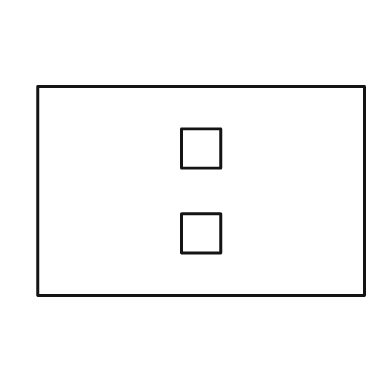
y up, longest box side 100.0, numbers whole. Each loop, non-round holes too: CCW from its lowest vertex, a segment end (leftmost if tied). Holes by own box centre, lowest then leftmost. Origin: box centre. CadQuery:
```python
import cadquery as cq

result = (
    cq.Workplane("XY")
    .moveTo(-50.0, -32.0)
    .lineTo(50.0, -32.0)
    .lineTo(50.0, 32.0)
    .lineTo(-50.0, 32.0)
    .close()
    .moveTo(-6.0, -19.0)
    .lineTo(6.0, -19.0)
    .lineTo(6.0, -7.0)
    .lineTo(-6.0, -7.0)
    .close()
    .moveTo(-6.0, 7.0)
    .lineTo(6.0, 7.0)
    .lineTo(6.0, 19.0)
    .lineTo(-6.0, 19.0)
    .close()
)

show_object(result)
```